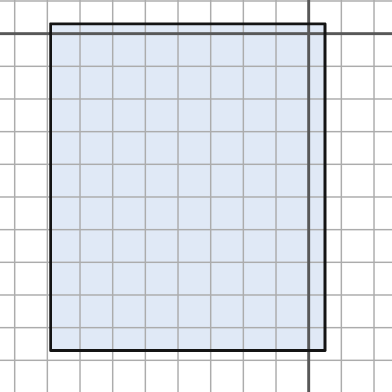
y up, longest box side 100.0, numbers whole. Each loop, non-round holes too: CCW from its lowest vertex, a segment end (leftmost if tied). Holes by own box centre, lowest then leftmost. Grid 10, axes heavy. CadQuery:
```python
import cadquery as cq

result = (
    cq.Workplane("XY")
    .moveTo(-79.0, -97.0)
    .lineTo(5.0, -97.0)
    .lineTo(5.0, 3.0)
    .lineTo(-79.0, 3.0)
    .close()
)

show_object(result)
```